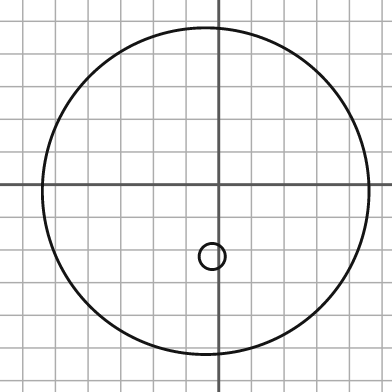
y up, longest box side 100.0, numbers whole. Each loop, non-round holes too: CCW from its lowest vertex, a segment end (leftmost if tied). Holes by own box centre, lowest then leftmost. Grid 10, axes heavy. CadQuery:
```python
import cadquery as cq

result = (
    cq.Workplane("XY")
    .moveTo(-4.0, -2.0)
    .circle(50.0)
    .moveTo(-2.0, -22.0)
    .circle(4.0)
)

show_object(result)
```